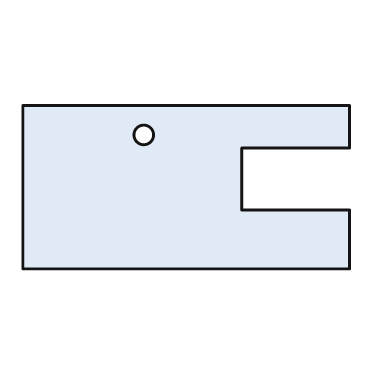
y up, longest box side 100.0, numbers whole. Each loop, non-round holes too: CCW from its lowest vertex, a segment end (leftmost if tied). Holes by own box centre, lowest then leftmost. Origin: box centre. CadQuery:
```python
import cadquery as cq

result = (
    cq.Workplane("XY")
    .moveTo(-50.0, -25.0)
    .lineTo(50.0, -25.0)
    .lineTo(50.0, -7.0)
    .lineTo(17.0, -7.0)
    .lineTo(17.0, 12.0)
    .lineTo(50.0, 12.0)
    .lineTo(50.0, 25.0)
    .lineTo(-50.0, 25.0)
    .close()
    .moveTo(-13.0, 16.0)
    .circle(3.0)
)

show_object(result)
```